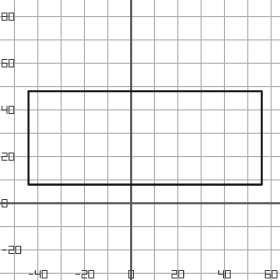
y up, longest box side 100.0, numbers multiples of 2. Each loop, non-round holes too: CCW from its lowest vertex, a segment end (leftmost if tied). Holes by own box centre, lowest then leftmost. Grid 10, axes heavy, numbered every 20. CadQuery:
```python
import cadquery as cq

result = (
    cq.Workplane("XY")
    .moveTo(-44.0, 8.0)
    .lineTo(56.0, 8.0)
    .lineTo(56.0, 48.0)
    .lineTo(-44.0, 48.0)
    .close()
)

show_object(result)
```